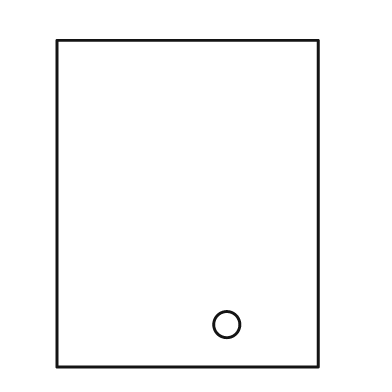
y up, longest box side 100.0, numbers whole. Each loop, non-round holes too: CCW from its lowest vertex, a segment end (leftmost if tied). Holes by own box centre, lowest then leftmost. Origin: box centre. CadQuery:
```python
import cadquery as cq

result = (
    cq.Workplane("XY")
    .moveTo(-40.0, -50.0)
    .lineTo(40.0, -50.0)
    .lineTo(40.0, 50.0)
    .lineTo(-40.0, 50.0)
    .close()
    .moveTo(12.0, -37.0)
    .circle(4.0)
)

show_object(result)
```